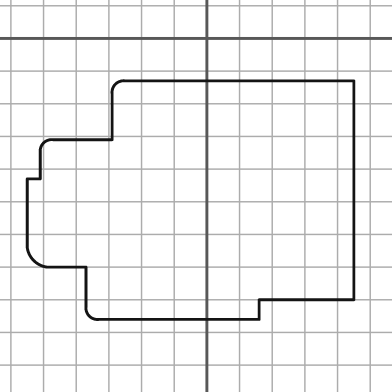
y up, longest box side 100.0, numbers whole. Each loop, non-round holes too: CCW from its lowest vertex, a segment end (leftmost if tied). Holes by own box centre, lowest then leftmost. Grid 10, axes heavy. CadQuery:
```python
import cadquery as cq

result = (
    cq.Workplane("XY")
    .moveTo(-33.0, -86.0)
    .lineTo(16.0, -86.0)
    .lineTo(16.0, -80.0)
    .lineTo(45.0, -80.0)
    .lineTo(45.0, -13.0)
    .lineTo(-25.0, -13.0)
    .threePointArc((-28.0, -14.0), (-29.0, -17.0))
    .lineTo(-29.0, -31.0)
    .lineTo(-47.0, -31.0)
    .threePointArc((-50.0, -32.0), (-51.0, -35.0))
    .lineTo(-51.0, -43.0)
    .lineTo(-55.0, -43.0)
    .lineTo(-55.0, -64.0)
    .threePointArc((-53.0, -68.0), (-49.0, -70.0))
    .lineTo(-37.0, -70.0)
    .lineTo(-37.0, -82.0)
    .threePointArc((-36.0, -85.0), (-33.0, -86.0))
    .close()
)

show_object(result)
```